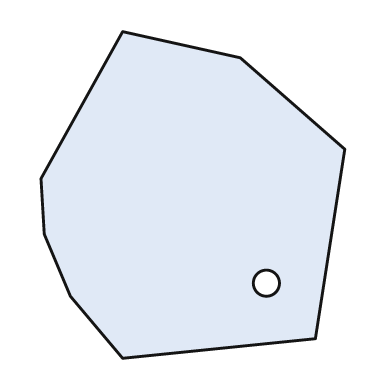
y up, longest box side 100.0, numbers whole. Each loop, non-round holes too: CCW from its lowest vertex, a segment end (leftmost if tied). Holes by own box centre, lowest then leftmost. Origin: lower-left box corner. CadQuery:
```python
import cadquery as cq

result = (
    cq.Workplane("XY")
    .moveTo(25.0, 0.0)
    .lineTo(84.0, 6.0)
    .lineTo(93.0, 64.0)
    .lineTo(61.0, 92.0)
    .lineTo(25.0, 100.0)
    .lineTo(0.0, 55.0)
    .lineTo(1.0, 38.0)
    .lineTo(9.0, 19.0)
    .close()
    .moveTo(69.0, 23.0)
    .circle(4.0)
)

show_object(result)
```